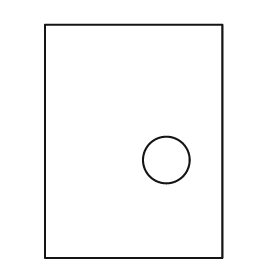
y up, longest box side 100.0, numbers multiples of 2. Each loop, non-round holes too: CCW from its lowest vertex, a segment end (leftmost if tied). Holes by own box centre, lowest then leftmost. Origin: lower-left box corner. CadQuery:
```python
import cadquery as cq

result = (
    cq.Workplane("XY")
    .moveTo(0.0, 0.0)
    .lineTo(76.0, 0.0)
    .lineTo(76.0, 100.0)
    .lineTo(0.0, 100.0)
    .close()
    .moveTo(52.0, 42.0)
    .circle(10.0)
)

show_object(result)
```